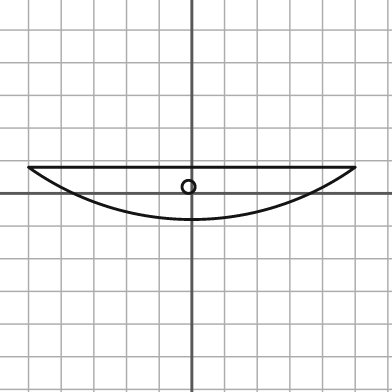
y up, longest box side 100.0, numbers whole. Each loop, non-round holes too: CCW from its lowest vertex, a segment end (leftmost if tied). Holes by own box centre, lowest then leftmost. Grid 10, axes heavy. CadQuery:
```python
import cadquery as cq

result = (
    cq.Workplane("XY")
    .moveTo(-50.0, 8.0)
    .threePointArc((0.0, -8.0), (50.0, 8.0))
    .close()
    .moveTo(-1.0, 2.0)
    .circle(2.0)
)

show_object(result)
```